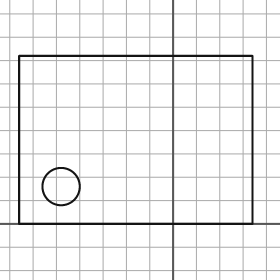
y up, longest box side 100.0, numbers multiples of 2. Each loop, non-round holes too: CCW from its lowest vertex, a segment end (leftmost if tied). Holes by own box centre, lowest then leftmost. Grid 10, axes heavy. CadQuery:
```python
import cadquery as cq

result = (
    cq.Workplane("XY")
    .moveTo(-66.0, 0.0)
    .lineTo(34.0, 0.0)
    .lineTo(34.0, 72.0)
    .lineTo(-66.0, 72.0)
    .close()
    .moveTo(-48.0, 16.0)
    .circle(8.0)
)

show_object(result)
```